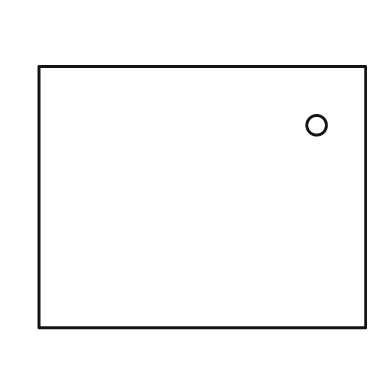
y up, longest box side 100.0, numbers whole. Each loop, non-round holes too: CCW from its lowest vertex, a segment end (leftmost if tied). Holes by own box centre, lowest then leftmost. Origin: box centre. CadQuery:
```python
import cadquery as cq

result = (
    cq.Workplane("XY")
    .moveTo(-50.0, -40.0)
    .lineTo(50.0, -40.0)
    .lineTo(50.0, 40.0)
    .lineTo(-50.0, 40.0)
    .close()
    .moveTo(35.0, 22.0)
    .circle(3.0)
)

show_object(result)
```